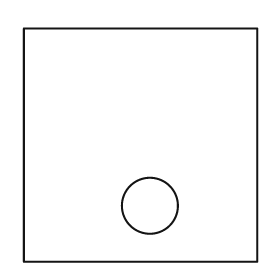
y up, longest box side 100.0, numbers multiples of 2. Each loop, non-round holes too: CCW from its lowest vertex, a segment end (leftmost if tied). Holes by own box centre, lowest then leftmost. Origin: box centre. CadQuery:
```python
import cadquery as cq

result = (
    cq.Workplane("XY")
    .moveTo(-50.0, -50.0)
    .lineTo(50.0, -50.0)
    .lineTo(50.0, 50.0)
    .lineTo(-50.0, 50.0)
    .close()
    .moveTo(4.0, -26.0)
    .circle(12.0)
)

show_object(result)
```